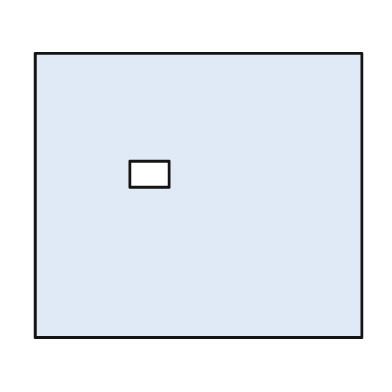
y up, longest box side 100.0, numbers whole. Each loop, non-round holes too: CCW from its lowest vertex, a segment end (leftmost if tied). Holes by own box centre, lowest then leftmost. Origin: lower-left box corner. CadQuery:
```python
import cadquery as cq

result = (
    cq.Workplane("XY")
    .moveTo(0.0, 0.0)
    .lineTo(100.0, 0.0)
    .lineTo(100.0, 87.0)
    .lineTo(0.0, 87.0)
    .close()
    .moveTo(29.0, 46.0)
    .lineTo(41.0, 46.0)
    .lineTo(41.0, 54.0)
    .lineTo(29.0, 54.0)
    .close()
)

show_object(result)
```